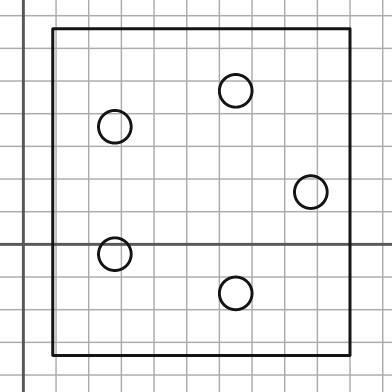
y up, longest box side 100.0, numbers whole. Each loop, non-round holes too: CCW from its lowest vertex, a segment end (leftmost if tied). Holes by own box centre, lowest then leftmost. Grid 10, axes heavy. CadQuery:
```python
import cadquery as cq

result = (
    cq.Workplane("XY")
    .moveTo(9.0, -34.0)
    .lineTo(100.0, -34.0)
    .lineTo(100.0, 66.0)
    .lineTo(9.0, 66.0)
    .close()
    .moveTo(65.0, -15.0)
    .circle(5.0)
    .moveTo(28.0, -3.0)
    .circle(5.0)
    .moveTo(88.0, 16.0)
    .circle(5.0)
    .moveTo(28.0, 36.0)
    .circle(5.0)
    .moveTo(65.0, 47.0)
    .circle(5.0)
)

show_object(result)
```